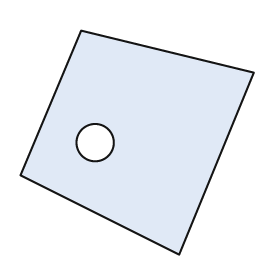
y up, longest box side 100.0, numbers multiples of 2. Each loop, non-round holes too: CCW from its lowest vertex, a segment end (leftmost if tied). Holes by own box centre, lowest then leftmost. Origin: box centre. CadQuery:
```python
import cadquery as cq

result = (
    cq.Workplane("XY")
    .moveTo(18.0, -48.0)
    .lineTo(50.0, 30.0)
    .lineTo(-24.0, 48.0)
    .lineTo(-50.0, -14.0)
    .close()
    .moveTo(-18.0, 0.0)
    .circle(8.0)
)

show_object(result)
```